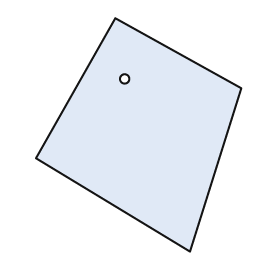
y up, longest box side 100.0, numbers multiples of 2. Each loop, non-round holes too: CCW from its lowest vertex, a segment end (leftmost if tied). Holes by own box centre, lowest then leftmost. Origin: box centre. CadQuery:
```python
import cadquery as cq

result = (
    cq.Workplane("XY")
    .moveTo(22.0, -50.0)
    .lineTo(44.0, 20.0)
    .lineTo(-10.0, 50.0)
    .lineTo(-44.0, -10.0)
    .close()
    .moveTo(-6.0, 24.0)
    .circle(2.0)
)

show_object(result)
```